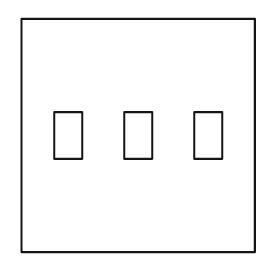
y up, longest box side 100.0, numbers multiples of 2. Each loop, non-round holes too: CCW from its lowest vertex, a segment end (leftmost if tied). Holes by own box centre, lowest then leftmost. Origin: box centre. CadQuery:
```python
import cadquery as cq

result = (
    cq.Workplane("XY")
    .moveTo(-50.0, -50.0)
    .lineTo(50.0, -50.0)
    .lineTo(50.0, 50.0)
    .lineTo(-50.0, 50.0)
    .close()
    .moveTo(-36.0, -10.0)
    .lineTo(-24.0, -10.0)
    .lineTo(-24.0, 10.0)
    .lineTo(-36.0, 10.0)
    .close()
    .moveTo(-6.0, -10.0)
    .lineTo(6.0, -10.0)
    .lineTo(6.0, 10.0)
    .lineTo(-6.0, 10.0)
    .close()
    .moveTo(24.0, -10.0)
    .lineTo(36.0, -10.0)
    .lineTo(36.0, 10.0)
    .lineTo(24.0, 10.0)
    .close()
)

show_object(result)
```